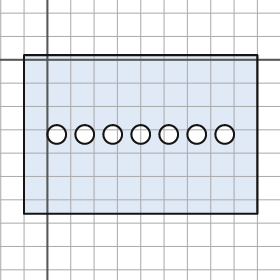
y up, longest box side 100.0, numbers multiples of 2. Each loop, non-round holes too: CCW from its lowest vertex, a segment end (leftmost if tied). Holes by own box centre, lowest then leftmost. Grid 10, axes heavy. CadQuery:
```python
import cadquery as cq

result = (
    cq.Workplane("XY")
    .moveTo(-10.0, -66.0)
    .lineTo(90.0, -66.0)
    .lineTo(90.0, 2.0)
    .lineTo(-10.0, 2.0)
    .close()
    .moveTo(4.0, -32.0)
    .circle(4.0)
    .moveTo(16.0, -32.0)
    .circle(4.0)
    .moveTo(28.0, -32.0)
    .circle(4.0)
    .moveTo(40.0, -32.0)
    .circle(4.0)
    .moveTo(52.0, -32.0)
    .circle(4.0)
    .moveTo(64.0, -32.0)
    .circle(4.0)
    .moveTo(76.0, -32.0)
    .circle(4.0)
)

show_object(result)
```